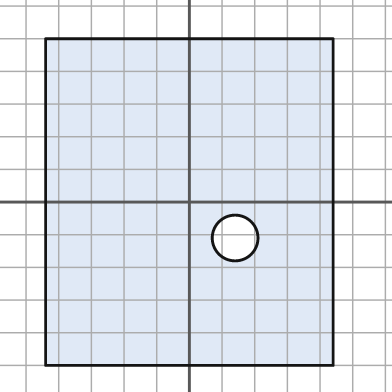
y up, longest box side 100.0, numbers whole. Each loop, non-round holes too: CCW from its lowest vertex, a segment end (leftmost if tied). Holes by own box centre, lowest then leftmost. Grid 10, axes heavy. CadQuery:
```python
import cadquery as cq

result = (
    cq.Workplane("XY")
    .moveTo(-44.0, -50.0)
    .lineTo(44.0, -50.0)
    .lineTo(44.0, 50.0)
    .lineTo(-44.0, 50.0)
    .close()
    .moveTo(14.0, -11.0)
    .circle(7.0)
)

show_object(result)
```